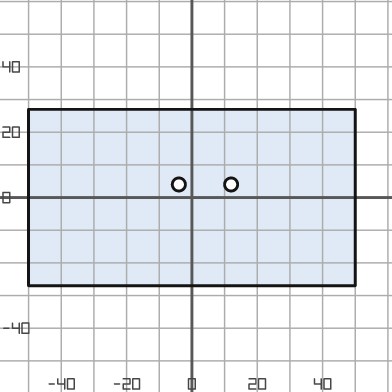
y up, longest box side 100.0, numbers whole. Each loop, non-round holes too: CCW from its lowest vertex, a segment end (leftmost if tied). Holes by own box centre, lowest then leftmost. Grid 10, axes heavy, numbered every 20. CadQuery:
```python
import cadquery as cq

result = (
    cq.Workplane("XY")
    .moveTo(-50.0, -27.0)
    .lineTo(50.0, -27.0)
    .lineTo(50.0, 27.0)
    .lineTo(-50.0, 27.0)
    .close()
    .moveTo(-4.0, 4.0)
    .circle(2.0)
    .moveTo(12.0, 4.0)
    .circle(2.0)
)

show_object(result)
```